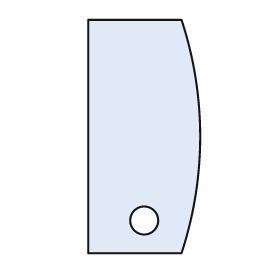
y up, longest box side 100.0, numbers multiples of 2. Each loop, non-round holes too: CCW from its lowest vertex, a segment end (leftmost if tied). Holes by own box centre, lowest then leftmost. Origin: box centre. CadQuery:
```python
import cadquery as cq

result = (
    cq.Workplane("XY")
    .moveTo(-24.0, -50.0)
    .lineTo(16.0, -50.0)
    .threePointArc((24.0, 0.0), (16.0, 50.0))
    .lineTo(-24.0, 50.0)
    .close()
    .moveTo(0.0, -36.0)
    .circle(6.0)
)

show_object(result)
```